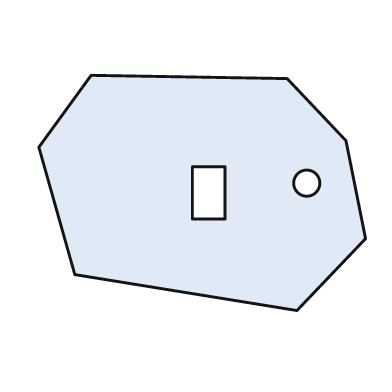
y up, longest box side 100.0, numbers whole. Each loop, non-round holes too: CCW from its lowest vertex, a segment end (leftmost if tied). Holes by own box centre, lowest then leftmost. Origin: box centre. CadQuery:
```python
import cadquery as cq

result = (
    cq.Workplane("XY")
    .moveTo(29.0, -36.0)
    .lineTo(50.0, -14.0)
    .lineTo(44.0, 16.0)
    .lineTo(26.0, 35.0)
    .lineTo(-34.0, 36.0)
    .lineTo(-50.0, 14.0)
    .lineTo(-39.0, -25.0)
    .close()
    .moveTo(-3.0, -8.0)
    .lineTo(7.0, -8.0)
    .lineTo(7.0, 8.0)
    .lineTo(-3.0, 8.0)
    .close()
    .moveTo(32.0, 3.0)
    .circle(4.0)
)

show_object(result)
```